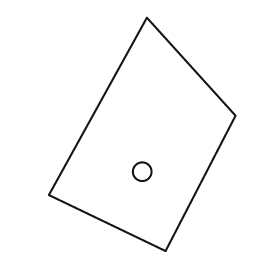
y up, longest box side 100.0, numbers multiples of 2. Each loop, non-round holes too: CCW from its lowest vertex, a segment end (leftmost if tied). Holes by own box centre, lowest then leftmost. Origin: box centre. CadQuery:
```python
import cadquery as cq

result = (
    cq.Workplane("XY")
    .moveTo(10.0, -50.0)
    .lineTo(40.0, 8.0)
    .lineTo(2.0, 50.0)
    .lineTo(-40.0, -26.0)
    .close()
    .moveTo(0.0, -16.0)
    .circle(4.0)
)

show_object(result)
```